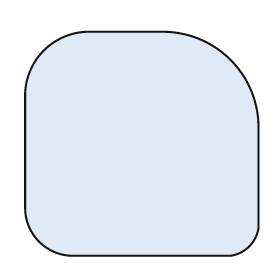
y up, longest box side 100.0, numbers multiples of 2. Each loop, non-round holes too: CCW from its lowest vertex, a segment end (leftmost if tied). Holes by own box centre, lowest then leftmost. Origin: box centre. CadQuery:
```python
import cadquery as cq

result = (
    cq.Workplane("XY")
    .moveTo(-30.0, -48.0)
    .lineTo(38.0, -48.0)
    .threePointArc((46.0, -44.0), (50.0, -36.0))
    .lineTo(50.0, 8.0)
    .threePointArc((38.0, 36.0), (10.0, 48.0))
    .lineTo(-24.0, 48.0)
    .threePointArc((-42.0, 40.0), (-50.0, 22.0))
    .lineTo(-50.0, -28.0)
    .threePointArc((-44.0, -42.0), (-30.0, -48.0))
    .close()
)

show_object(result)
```